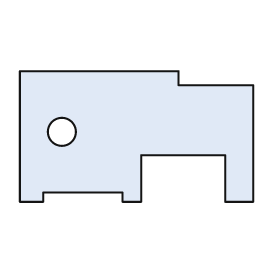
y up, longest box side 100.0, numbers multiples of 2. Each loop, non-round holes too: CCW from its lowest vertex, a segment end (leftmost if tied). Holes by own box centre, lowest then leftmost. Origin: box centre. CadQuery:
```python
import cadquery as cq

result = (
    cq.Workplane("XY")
    .moveTo(-50.0, -28.0)
    .lineTo(-40.0, -28.0)
    .lineTo(-40.0, -24.0)
    .lineTo(-6.0, -24.0)
    .lineTo(-6.0, -28.0)
    .lineTo(2.0, -28.0)
    .lineTo(2.0, -8.0)
    .lineTo(38.0, -8.0)
    .lineTo(38.0, -28.0)
    .lineTo(50.0, -28.0)
    .lineTo(50.0, 22.0)
    .lineTo(18.0, 22.0)
    .lineTo(18.0, 28.0)
    .lineTo(-50.0, 28.0)
    .close()
    .moveTo(-32.0, 2.0)
    .circle(6.0)
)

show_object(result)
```